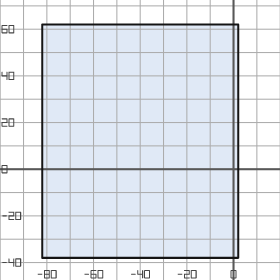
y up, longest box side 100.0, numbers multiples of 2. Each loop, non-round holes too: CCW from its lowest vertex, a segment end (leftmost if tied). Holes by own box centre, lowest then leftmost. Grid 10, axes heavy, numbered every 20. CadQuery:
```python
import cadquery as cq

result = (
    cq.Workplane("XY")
    .moveTo(-82.0, -38.0)
    .lineTo(2.0, -38.0)
    .lineTo(2.0, 62.0)
    .lineTo(-82.0, 62.0)
    .close()
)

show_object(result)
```